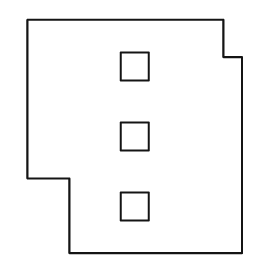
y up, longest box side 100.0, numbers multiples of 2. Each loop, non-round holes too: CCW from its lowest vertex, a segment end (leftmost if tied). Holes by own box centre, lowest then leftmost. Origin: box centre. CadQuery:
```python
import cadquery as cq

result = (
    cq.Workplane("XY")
    .moveTo(-28.0, -50.0)
    .lineTo(46.0, -50.0)
    .lineTo(46.0, 34.0)
    .lineTo(38.0, 34.0)
    .lineTo(38.0, 50.0)
    .lineTo(-46.0, 50.0)
    .lineTo(-46.0, -18.0)
    .lineTo(-28.0, -18.0)
    .close()
    .moveTo(-6.0, -36.0)
    .lineTo(6.0, -36.0)
    .lineTo(6.0, -24.0)
    .lineTo(-6.0, -24.0)
    .close()
    .moveTo(-6.0, -6.0)
    .lineTo(6.0, -6.0)
    .lineTo(6.0, 6.0)
    .lineTo(-6.0, 6.0)
    .close()
    .moveTo(-6.0, 24.0)
    .lineTo(6.0, 24.0)
    .lineTo(6.0, 36.0)
    .lineTo(-6.0, 36.0)
    .close()
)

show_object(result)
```